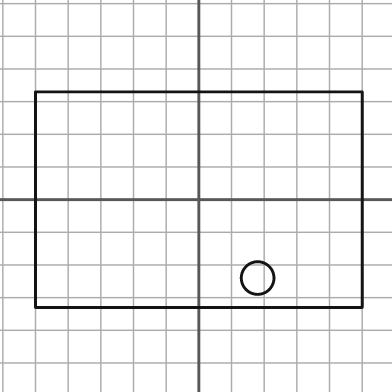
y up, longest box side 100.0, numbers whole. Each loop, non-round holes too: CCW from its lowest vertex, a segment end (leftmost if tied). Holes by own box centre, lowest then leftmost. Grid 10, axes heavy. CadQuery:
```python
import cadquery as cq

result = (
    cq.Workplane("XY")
    .moveTo(-50.0, -33.0)
    .lineTo(50.0, -33.0)
    .lineTo(50.0, 33.0)
    .lineTo(-50.0, 33.0)
    .close()
    .moveTo(18.0, -24.0)
    .circle(5.0)
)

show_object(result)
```